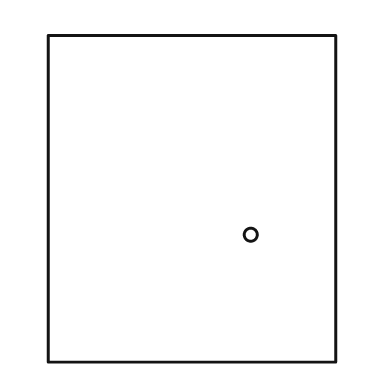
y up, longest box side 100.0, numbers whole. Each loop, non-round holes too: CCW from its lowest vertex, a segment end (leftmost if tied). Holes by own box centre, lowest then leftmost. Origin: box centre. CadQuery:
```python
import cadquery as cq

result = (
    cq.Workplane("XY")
    .moveTo(-44.0, -50.0)
    .lineTo(44.0, -50.0)
    .lineTo(44.0, 50.0)
    .lineTo(-44.0, 50.0)
    .close()
    .moveTo(18.0, -11.0)
    .circle(2.0)
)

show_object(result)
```